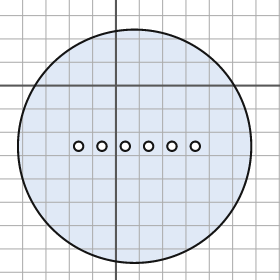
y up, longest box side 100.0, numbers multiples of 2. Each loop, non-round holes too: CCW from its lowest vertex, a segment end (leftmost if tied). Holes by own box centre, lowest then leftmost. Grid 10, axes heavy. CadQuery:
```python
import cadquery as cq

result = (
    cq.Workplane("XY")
    .moveTo(8.0, -26.0)
    .circle(50.0)
    .moveTo(-16.0, -26.0)
    .circle(2.0)
    .moveTo(-6.0, -26.0)
    .circle(2.0)
    .moveTo(4.0, -26.0)
    .circle(2.0)
    .moveTo(14.0, -26.0)
    .circle(2.0)
    .moveTo(24.0, -26.0)
    .circle(2.0)
    .moveTo(34.0, -26.0)
    .circle(2.0)
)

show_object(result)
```